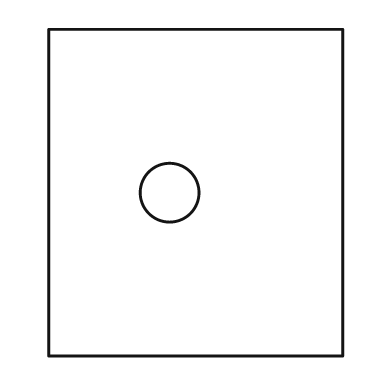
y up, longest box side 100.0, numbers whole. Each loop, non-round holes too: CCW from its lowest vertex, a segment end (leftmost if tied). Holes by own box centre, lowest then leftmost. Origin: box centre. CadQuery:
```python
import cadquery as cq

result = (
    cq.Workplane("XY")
    .moveTo(-45.0, -50.0)
    .lineTo(45.0, -50.0)
    .lineTo(45.0, 50.0)
    .lineTo(-45.0, 50.0)
    .close()
    .moveTo(-8.0, 0.0)
    .circle(9.0)
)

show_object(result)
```